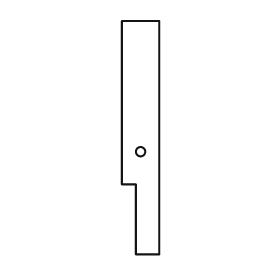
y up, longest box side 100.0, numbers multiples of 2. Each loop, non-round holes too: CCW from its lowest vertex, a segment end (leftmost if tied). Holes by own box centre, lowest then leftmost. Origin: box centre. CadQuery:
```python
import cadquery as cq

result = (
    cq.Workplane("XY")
    .moveTo(-2.0, -50.0)
    .lineTo(8.0, -50.0)
    .lineTo(8.0, 50.0)
    .lineTo(-8.0, 50.0)
    .lineTo(-8.0, -20.0)
    .lineTo(-2.0, -20.0)
    .close()
    .moveTo(0.0, -6.0)
    .circle(2.0)
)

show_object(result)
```